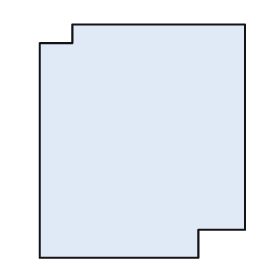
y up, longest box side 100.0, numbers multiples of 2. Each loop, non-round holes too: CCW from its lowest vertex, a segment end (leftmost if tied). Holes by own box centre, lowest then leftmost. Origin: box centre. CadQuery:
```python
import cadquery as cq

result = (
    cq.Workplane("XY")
    .moveTo(-44.0, -50.0)
    .lineTo(24.0, -50.0)
    .lineTo(24.0, -38.0)
    .lineTo(44.0, -38.0)
    .lineTo(44.0, 50.0)
    .lineTo(-30.0, 50.0)
    .lineTo(-30.0, 42.0)
    .lineTo(-44.0, 42.0)
    .close()
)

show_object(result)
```